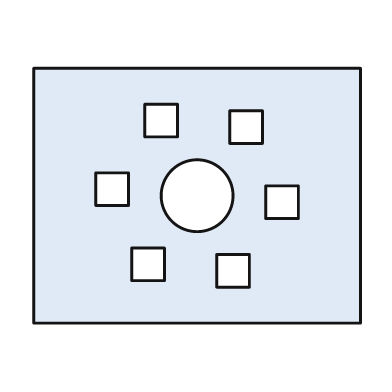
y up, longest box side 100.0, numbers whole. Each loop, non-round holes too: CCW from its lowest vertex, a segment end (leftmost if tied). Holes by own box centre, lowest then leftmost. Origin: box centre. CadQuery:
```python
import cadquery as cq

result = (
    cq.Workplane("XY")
    .moveTo(-50.0, -39.0)
    .lineTo(50.0, -39.0)
    .lineTo(50.0, 39.0)
    .lineTo(-50.0, 39.0)
    .close()
    .moveTo(6.0, -28.0)
    .lineTo(16.0, -28.0)
    .lineTo(16.0, -18.0)
    .lineTo(6.0, -18.0)
    .close()
    .moveTo(-20.0, -26.0)
    .lineTo(-10.0, -26.0)
    .lineTo(-10.0, -16.0)
    .lineTo(-20.0, -16.0)
    .close()
    .moveTo(21.0, -7.0)
    .lineTo(31.0, -7.0)
    .lineTo(31.0, 3.0)
    .lineTo(21.0, 3.0)
    .close()
    .moveTo(0.0, 0.0)
    .circle(11.0)
    .moveTo(-31.0, -3.0)
    .lineTo(-21.0, -3.0)
    .lineTo(-21.0, 7.0)
    .lineTo(-31.0, 7.0)
    .close()
    .moveTo(10.0, 16.0)
    .lineTo(20.0, 16.0)
    .lineTo(20.0, 26.0)
    .lineTo(10.0, 26.0)
    .close()
    .moveTo(-16.0, 18.0)
    .lineTo(-6.0, 18.0)
    .lineTo(-6.0, 28.0)
    .lineTo(-16.0, 28.0)
    .close()
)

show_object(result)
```